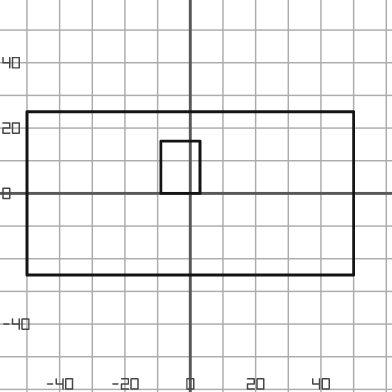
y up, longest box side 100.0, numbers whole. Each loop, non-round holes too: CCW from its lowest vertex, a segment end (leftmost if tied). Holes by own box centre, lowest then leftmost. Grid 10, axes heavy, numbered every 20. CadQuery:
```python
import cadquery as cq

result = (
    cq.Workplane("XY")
    .moveTo(-50.0, -25.0)
    .lineTo(50.0, -25.0)
    .lineTo(50.0, 25.0)
    .lineTo(-50.0, 25.0)
    .close()
    .moveTo(-9.0, 0.0)
    .lineTo(3.0, 0.0)
    .lineTo(3.0, 16.0)
    .lineTo(-9.0, 16.0)
    .close()
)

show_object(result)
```